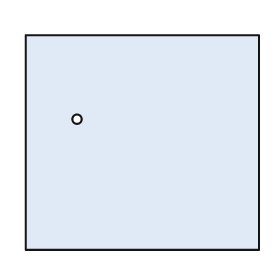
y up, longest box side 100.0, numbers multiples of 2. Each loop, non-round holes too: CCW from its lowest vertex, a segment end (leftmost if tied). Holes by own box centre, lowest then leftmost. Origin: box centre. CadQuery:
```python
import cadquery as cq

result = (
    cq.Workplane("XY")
    .moveTo(-50.0, -46.0)
    .lineTo(50.0, -46.0)
    .lineTo(50.0, 46.0)
    .lineTo(-50.0, 46.0)
    .close()
    .moveTo(-28.0, 10.0)
    .circle(2.0)
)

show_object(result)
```